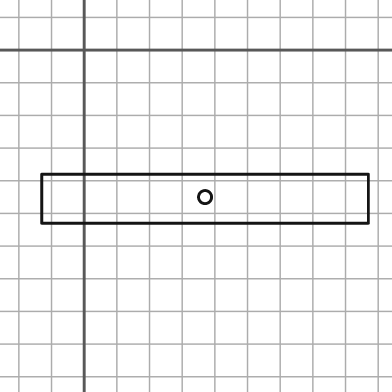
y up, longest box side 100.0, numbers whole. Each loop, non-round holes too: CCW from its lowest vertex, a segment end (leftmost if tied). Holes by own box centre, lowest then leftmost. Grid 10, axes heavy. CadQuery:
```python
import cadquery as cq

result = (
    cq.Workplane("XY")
    .moveTo(-13.0, -53.0)
    .lineTo(87.0, -53.0)
    .lineTo(87.0, -38.0)
    .lineTo(-13.0, -38.0)
    .close()
    .moveTo(37.0, -45.0)
    .circle(2.0)
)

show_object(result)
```